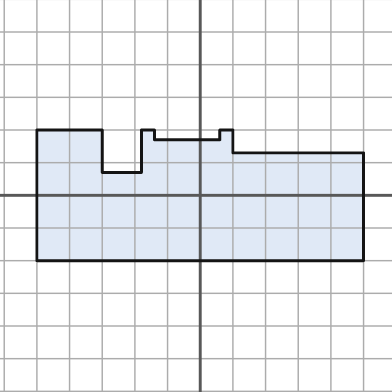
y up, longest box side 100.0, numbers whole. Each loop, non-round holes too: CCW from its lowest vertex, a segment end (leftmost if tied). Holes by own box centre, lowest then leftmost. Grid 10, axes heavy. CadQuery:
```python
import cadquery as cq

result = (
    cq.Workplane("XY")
    .moveTo(-50.0, -20.0)
    .lineTo(50.0, -20.0)
    .lineTo(50.0, 13.0)
    .lineTo(10.0, 13.0)
    .lineTo(10.0, 20.0)
    .lineTo(6.0, 20.0)
    .lineTo(6.0, 17.0)
    .lineTo(-14.0, 17.0)
    .lineTo(-14.0, 20.0)
    .lineTo(-18.0, 20.0)
    .lineTo(-18.0, 7.0)
    .lineTo(-30.0, 7.0)
    .lineTo(-30.0, 20.0)
    .lineTo(-50.0, 20.0)
    .close()
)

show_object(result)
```